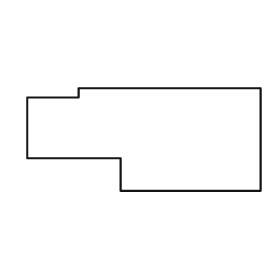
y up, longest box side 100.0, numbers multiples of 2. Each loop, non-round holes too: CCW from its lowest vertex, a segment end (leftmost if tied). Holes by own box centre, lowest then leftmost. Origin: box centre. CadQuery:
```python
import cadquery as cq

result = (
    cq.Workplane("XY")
    .moveTo(-10.0, -22.0)
    .lineTo(50.0, -22.0)
    .lineTo(50.0, 22.0)
    .lineTo(-28.0, 22.0)
    .lineTo(-28.0, 18.0)
    .lineTo(-50.0, 18.0)
    .lineTo(-50.0, -8.0)
    .lineTo(-10.0, -8.0)
    .close()
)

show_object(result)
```